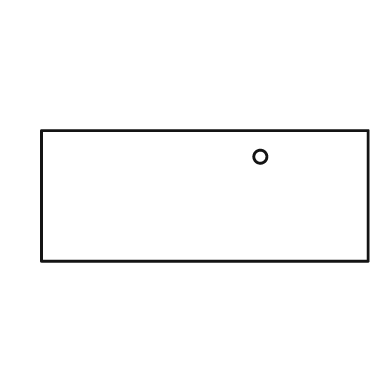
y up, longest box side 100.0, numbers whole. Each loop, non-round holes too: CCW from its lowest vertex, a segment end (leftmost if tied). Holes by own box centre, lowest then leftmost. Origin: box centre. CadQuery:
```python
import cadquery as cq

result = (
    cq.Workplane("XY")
    .moveTo(-50.0, -20.0)
    .lineTo(50.0, -20.0)
    .lineTo(50.0, 20.0)
    .lineTo(-50.0, 20.0)
    .close()
    .moveTo(17.0, 12.0)
    .circle(2.0)
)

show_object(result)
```